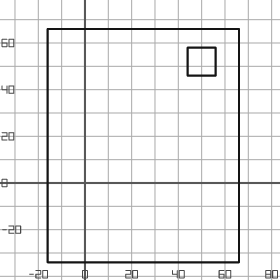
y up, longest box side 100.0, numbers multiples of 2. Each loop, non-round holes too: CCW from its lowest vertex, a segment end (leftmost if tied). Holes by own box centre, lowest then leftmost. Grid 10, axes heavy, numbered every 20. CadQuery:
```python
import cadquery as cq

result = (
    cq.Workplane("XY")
    .moveTo(-16.0, -34.0)
    .lineTo(66.0, -34.0)
    .lineTo(66.0, 66.0)
    .lineTo(-16.0, 66.0)
    .close()
    .moveTo(44.0, 46.0)
    .lineTo(56.0, 46.0)
    .lineTo(56.0, 58.0)
    .lineTo(44.0, 58.0)
    .close()
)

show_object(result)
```